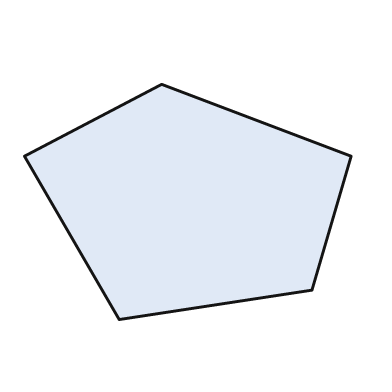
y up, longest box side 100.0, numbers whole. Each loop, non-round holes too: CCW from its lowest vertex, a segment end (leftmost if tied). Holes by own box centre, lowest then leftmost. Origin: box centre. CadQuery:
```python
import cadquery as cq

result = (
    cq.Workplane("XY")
    .moveTo(-21.0, -36.0)
    .lineTo(38.0, -27.0)
    .lineTo(50.0, 14.0)
    .lineTo(-8.0, 36.0)
    .lineTo(-50.0, 14.0)
    .close()
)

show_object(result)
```